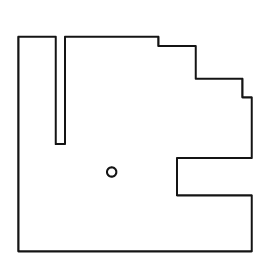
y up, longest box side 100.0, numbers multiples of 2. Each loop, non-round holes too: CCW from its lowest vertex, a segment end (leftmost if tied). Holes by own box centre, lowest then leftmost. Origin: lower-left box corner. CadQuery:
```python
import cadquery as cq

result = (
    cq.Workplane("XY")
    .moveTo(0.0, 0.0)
    .lineTo(100.0, 0.0)
    .lineTo(100.0, 24.0)
    .lineTo(68.0, 24.0)
    .lineTo(68.0, 40.0)
    .lineTo(100.0, 40.0)
    .lineTo(100.0, 66.0)
    .lineTo(96.0, 66.0)
    .lineTo(96.0, 74.0)
    .lineTo(76.0, 74.0)
    .lineTo(76.0, 88.0)
    .lineTo(60.0, 88.0)
    .lineTo(60.0, 92.0)
    .lineTo(20.0, 92.0)
    .lineTo(20.0, 46.0)
    .lineTo(16.0, 46.0)
    .lineTo(16.0, 92.0)
    .lineTo(0.0, 92.0)
    .close()
    .moveTo(40.0, 34.0)
    .circle(2.0)
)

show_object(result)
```